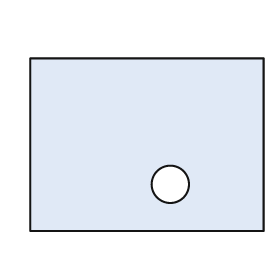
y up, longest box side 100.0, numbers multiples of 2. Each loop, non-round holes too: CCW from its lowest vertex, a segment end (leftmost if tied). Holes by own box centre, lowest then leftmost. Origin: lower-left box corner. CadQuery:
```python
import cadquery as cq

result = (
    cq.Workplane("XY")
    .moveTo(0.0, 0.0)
    .lineTo(100.0, 0.0)
    .lineTo(100.0, 74.0)
    .lineTo(0.0, 74.0)
    .close()
    .moveTo(60.0, 20.0)
    .circle(8.0)
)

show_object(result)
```